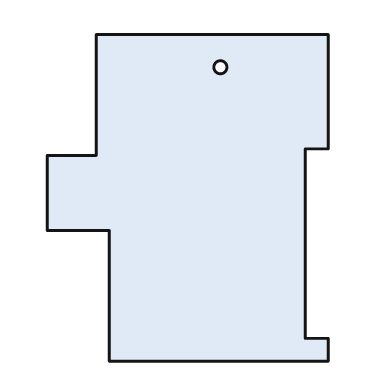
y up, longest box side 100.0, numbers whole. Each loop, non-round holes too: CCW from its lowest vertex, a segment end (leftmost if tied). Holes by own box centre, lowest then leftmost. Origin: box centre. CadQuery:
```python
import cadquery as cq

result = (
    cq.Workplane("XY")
    .moveTo(-24.0, -50.0)
    .lineTo(43.0, -50.0)
    .lineTo(43.0, -43.0)
    .lineTo(36.0, -43.0)
    .lineTo(36.0, 15.0)
    .lineTo(43.0, 15.0)
    .lineTo(43.0, 50.0)
    .lineTo(-28.0, 50.0)
    .lineTo(-28.0, 13.0)
    .lineTo(-43.0, 13.0)
    .lineTo(-43.0, -10.0)
    .lineTo(-24.0, -10.0)
    .close()
    .moveTo(10.0, 40.0)
    .circle(2.0)
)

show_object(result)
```